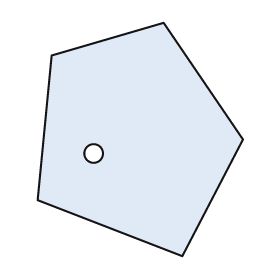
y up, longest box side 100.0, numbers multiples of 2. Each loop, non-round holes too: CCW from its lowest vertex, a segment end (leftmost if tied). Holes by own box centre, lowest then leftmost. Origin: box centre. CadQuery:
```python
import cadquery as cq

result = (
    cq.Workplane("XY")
    .moveTo(18.0, -50.0)
    .lineTo(44.0, 0.0)
    .lineTo(10.0, 50.0)
    .lineTo(-38.0, 36.0)
    .lineTo(-44.0, -26.0)
    .close()
    .moveTo(-20.0, -6.0)
    .circle(4.0)
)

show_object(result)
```